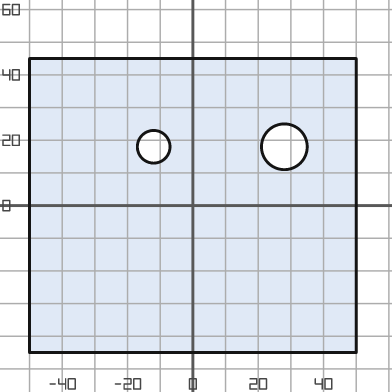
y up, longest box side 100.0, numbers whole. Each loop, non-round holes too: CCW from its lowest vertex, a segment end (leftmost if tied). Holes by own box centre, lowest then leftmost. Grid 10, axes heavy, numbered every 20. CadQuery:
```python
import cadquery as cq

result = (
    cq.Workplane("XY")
    .moveTo(-50.0, -45.0)
    .lineTo(50.0, -45.0)
    .lineTo(50.0, 45.0)
    .lineTo(-50.0, 45.0)
    .close()
    .moveTo(-12.0, 18.0)
    .circle(5.0)
    .moveTo(28.0, 18.0)
    .circle(7.0)
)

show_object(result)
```